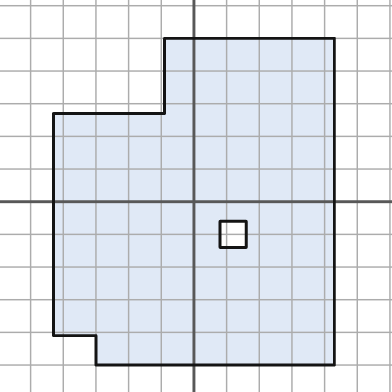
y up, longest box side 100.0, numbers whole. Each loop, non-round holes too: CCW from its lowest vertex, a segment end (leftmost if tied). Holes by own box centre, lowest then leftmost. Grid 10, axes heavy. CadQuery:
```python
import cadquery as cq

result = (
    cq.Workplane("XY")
    .moveTo(-30.0, -50.0)
    .lineTo(43.0, -50.0)
    .lineTo(43.0, 50.0)
    .lineTo(-9.0, 50.0)
    .lineTo(-9.0, 27.0)
    .lineTo(-43.0, 27.0)
    .lineTo(-43.0, -41.0)
    .lineTo(-30.0, -41.0)
    .close()
    .moveTo(8.0, -14.0)
    .lineTo(16.0, -14.0)
    .lineTo(16.0, -6.0)
    .lineTo(8.0, -6.0)
    .close()
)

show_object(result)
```